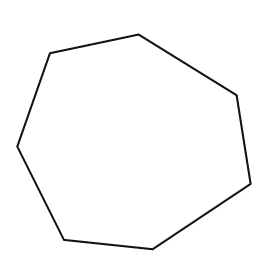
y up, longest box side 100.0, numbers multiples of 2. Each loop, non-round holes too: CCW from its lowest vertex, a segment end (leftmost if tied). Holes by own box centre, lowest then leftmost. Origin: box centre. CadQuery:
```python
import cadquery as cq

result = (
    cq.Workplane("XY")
    .moveTo(8.0, -46.0)
    .lineTo(50.0, -18.0)
    .lineTo(44.0, 20.0)
    .lineTo(2.0, 46.0)
    .lineTo(-36.0, 38.0)
    .lineTo(-50.0, -2.0)
    .lineTo(-30.0, -42.0)
    .close()
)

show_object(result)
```